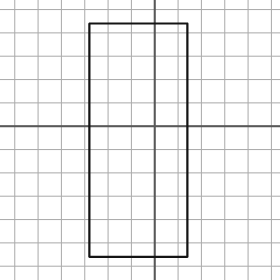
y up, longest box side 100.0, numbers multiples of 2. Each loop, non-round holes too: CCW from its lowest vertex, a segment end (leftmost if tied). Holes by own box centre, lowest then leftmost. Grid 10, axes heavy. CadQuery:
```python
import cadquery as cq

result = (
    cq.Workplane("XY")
    .moveTo(-28.0, -56.0)
    .lineTo(14.0, -56.0)
    .lineTo(14.0, 44.0)
    .lineTo(-28.0, 44.0)
    .close()
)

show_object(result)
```